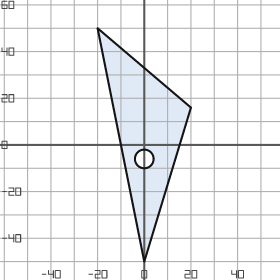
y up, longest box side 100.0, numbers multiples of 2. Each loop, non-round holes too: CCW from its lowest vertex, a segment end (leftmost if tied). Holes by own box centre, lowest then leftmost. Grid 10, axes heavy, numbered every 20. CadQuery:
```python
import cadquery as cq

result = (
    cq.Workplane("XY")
    .moveTo(0.0, -50.0)
    .lineTo(20.0, 16.0)
    .lineTo(-20.0, 50.0)
    .close()
    .moveTo(0.0, -6.0)
    .circle(4.0)
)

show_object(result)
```